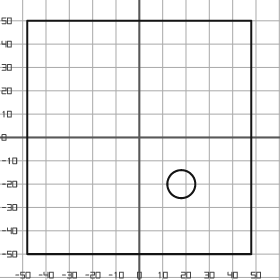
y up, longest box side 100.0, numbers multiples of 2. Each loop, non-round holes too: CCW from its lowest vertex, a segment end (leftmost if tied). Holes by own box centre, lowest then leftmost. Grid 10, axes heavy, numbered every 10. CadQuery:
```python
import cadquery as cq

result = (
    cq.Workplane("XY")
    .moveTo(-48.0, -50.0)
    .lineTo(48.0, -50.0)
    .lineTo(48.0, 50.0)
    .lineTo(-48.0, 50.0)
    .close()
    .moveTo(18.0, -20.0)
    .circle(6.0)
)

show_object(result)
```